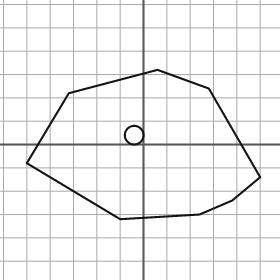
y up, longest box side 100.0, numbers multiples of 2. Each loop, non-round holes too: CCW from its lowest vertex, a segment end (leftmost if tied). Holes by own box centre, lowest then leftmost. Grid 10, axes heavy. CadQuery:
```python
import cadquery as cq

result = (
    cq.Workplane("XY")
    .moveTo(-10.0, -32.0)
    .lineTo(24.0, -30.0)
    .lineTo(38.0, -24.0)
    .lineTo(50.0, -14.0)
    .lineTo(28.0, 24.0)
    .lineTo(6.0, 32.0)
    .lineTo(-32.0, 22.0)
    .lineTo(-50.0, -8.0)
    .close()
    .moveTo(-4.0, 4.0)
    .circle(4.0)
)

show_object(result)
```